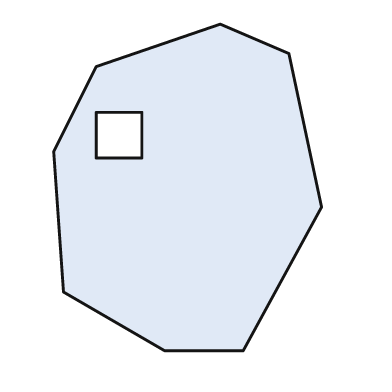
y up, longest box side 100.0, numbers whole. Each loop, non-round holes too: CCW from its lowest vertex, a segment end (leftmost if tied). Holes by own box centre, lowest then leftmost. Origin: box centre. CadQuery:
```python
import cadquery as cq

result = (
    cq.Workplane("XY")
    .moveTo(-7.0, -50.0)
    .lineTo(17.0, -50.0)
    .lineTo(41.0, -6.0)
    .lineTo(31.0, 41.0)
    .lineTo(10.0, 50.0)
    .lineTo(-28.0, 37.0)
    .lineTo(-41.0, 11.0)
    .lineTo(-38.0, -32.0)
    .close()
    .moveTo(-28.0, 9.0)
    .lineTo(-14.0, 9.0)
    .lineTo(-14.0, 23.0)
    .lineTo(-28.0, 23.0)
    .close()
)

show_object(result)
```